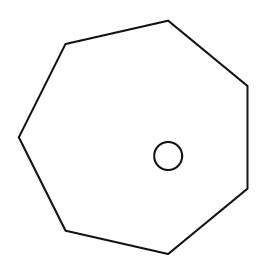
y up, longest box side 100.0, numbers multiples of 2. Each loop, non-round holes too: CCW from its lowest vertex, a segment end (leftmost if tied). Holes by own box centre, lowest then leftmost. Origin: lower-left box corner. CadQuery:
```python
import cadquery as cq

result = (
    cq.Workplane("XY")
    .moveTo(64.0, 0.0)
    .lineTo(98.0, 28.0)
    .lineTo(98.0, 72.0)
    .lineTo(64.0, 100.0)
    .lineTo(20.0, 90.0)
    .lineTo(0.0, 50.0)
    .lineTo(20.0, 10.0)
    .close()
    .moveTo(64.0, 42.0)
    .circle(6.0)
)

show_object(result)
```